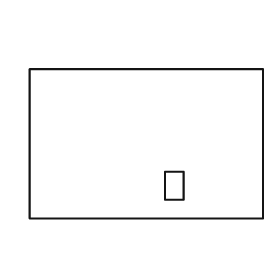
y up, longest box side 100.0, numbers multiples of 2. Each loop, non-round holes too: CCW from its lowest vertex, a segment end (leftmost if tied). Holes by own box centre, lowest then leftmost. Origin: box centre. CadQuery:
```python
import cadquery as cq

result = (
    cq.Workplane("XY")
    .moveTo(-50.0, -32.0)
    .lineTo(50.0, -32.0)
    .lineTo(50.0, 32.0)
    .lineTo(-50.0, 32.0)
    .close()
    .moveTo(8.0, -24.0)
    .lineTo(16.0, -24.0)
    .lineTo(16.0, -12.0)
    .lineTo(8.0, -12.0)
    .close()
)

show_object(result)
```